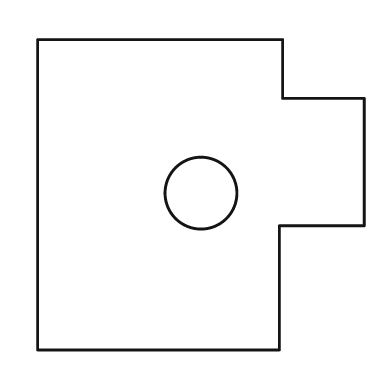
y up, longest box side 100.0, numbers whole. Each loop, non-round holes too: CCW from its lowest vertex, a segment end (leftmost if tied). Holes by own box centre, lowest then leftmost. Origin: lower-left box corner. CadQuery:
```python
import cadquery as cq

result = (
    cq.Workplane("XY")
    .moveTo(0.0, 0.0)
    .lineTo(74.0, 0.0)
    .lineTo(74.0, 38.0)
    .lineTo(100.0, 38.0)
    .lineTo(100.0, 77.0)
    .lineTo(75.0, 77.0)
    .lineTo(75.0, 95.0)
    .lineTo(0.0, 95.0)
    .close()
    .moveTo(50.0, 48.0)
    .circle(11.0)
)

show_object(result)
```